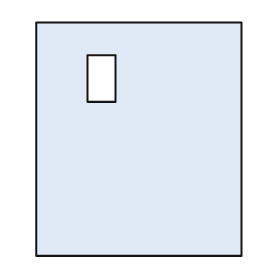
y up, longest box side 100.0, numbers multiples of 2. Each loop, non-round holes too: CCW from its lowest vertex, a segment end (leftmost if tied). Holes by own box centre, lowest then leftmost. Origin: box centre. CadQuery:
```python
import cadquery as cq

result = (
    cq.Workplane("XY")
    .moveTo(-44.0, -50.0)
    .lineTo(44.0, -50.0)
    .lineTo(44.0, 50.0)
    .lineTo(-44.0, 50.0)
    .close()
    .moveTo(-22.0, 16.0)
    .lineTo(-10.0, 16.0)
    .lineTo(-10.0, 36.0)
    .lineTo(-22.0, 36.0)
    .close()
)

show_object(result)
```